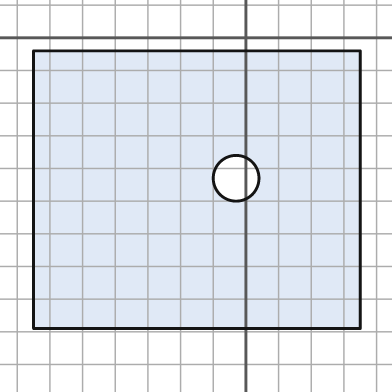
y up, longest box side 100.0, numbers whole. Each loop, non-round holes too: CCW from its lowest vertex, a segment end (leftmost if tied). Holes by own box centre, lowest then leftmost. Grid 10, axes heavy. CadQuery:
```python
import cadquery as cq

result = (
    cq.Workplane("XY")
    .moveTo(-65.0, -89.0)
    .lineTo(35.0, -89.0)
    .lineTo(35.0, -4.0)
    .lineTo(-65.0, -4.0)
    .close()
    .moveTo(-3.0, -43.0)
    .circle(7.0)
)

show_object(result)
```